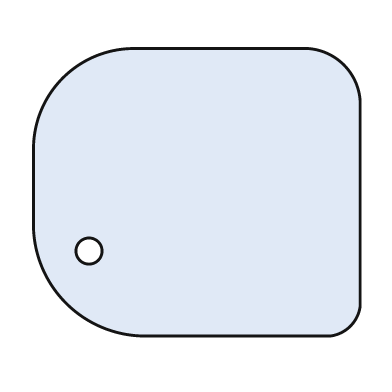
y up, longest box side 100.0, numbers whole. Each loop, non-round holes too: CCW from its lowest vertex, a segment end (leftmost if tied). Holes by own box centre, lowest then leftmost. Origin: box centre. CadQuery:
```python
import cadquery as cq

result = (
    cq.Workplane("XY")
    .moveTo(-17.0, -44.0)
    .lineTo(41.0, -44.0)
    .threePointArc((47.0, -41.0), (50.0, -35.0))
    .lineTo(50.0, 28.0)
    .threePointArc((45.0, 39.0), (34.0, 44.0))
    .lineTo(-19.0, 44.0)
    .threePointArc((-41.0, 35.0), (-50.0, 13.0))
    .lineTo(-50.0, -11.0)
    .threePointArc((-40.0, -34.0), (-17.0, -44.0))
    .close()
    .moveTo(-33.0, -18.0)
    .circle(4.0)
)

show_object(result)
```